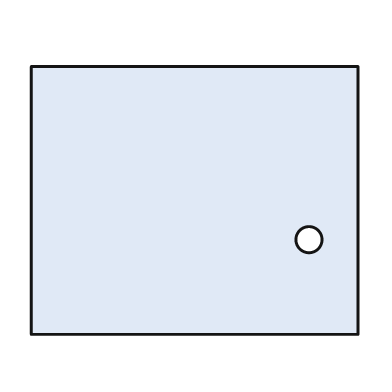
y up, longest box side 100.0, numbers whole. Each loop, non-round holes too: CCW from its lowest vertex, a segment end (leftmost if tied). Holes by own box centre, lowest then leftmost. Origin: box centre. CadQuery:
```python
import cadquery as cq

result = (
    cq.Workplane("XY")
    .moveTo(-50.0, -41.0)
    .lineTo(50.0, -41.0)
    .lineTo(50.0, 41.0)
    .lineTo(-50.0, 41.0)
    .close()
    .moveTo(35.0, -12.0)
    .circle(4.0)
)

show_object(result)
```